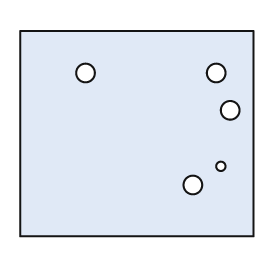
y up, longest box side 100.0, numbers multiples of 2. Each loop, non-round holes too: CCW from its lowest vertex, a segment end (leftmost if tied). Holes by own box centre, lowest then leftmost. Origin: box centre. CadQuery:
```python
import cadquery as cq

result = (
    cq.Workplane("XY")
    .moveTo(-50.0, -44.0)
    .lineTo(50.0, -44.0)
    .lineTo(50.0, 44.0)
    .lineTo(-50.0, 44.0)
    .close()
    .moveTo(24.0, -22.0)
    .circle(4.0)
    .moveTo(36.0, -14.0)
    .circle(2.0)
    .moveTo(40.0, 10.0)
    .circle(4.0)
    .moveTo(-22.0, 26.0)
    .circle(4.0)
    .moveTo(34.0, 26.0)
    .circle(4.0)
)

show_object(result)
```